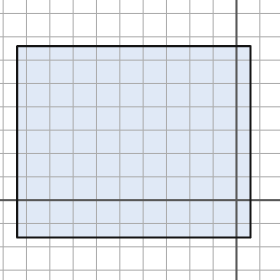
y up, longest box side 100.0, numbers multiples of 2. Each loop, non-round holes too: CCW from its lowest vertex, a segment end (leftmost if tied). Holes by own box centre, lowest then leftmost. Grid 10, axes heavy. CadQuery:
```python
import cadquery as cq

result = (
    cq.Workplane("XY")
    .moveTo(-94.0, -16.0)
    .lineTo(6.0, -16.0)
    .lineTo(6.0, 66.0)
    .lineTo(-94.0, 66.0)
    .close()
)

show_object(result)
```